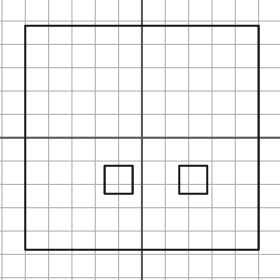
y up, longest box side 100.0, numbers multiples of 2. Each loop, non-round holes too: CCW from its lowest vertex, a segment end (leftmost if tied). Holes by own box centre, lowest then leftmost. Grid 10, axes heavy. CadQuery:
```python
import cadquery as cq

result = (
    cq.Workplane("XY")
    .moveTo(-50.0, -48.0)
    .lineTo(50.0, -48.0)
    .lineTo(50.0, 48.0)
    .lineTo(-50.0, 48.0)
    .close()
    .moveTo(-16.0, -24.0)
    .lineTo(-4.0, -24.0)
    .lineTo(-4.0, -12.0)
    .lineTo(-16.0, -12.0)
    .close()
    .moveTo(16.0, -24.0)
    .lineTo(28.0, -24.0)
    .lineTo(28.0, -12.0)
    .lineTo(16.0, -12.0)
    .close()
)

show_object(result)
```